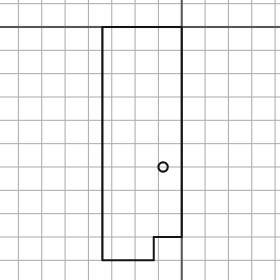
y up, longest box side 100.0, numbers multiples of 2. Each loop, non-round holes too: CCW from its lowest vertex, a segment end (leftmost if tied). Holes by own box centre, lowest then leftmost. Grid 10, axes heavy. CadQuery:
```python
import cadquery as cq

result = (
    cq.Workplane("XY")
    .moveTo(-34.0, -100.0)
    .lineTo(-12.0, -100.0)
    .lineTo(-12.0, -90.0)
    .lineTo(0.0, -90.0)
    .lineTo(0.0, 0.0)
    .lineTo(-34.0, 0.0)
    .close()
    .moveTo(-8.0, -60.0)
    .circle(2.0)
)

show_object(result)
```